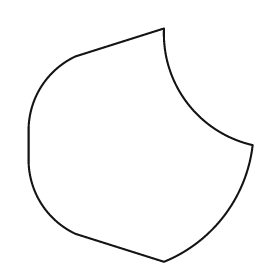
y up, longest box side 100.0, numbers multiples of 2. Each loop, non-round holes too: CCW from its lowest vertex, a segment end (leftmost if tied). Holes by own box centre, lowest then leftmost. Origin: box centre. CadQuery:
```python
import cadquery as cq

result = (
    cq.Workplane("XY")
    .moveTo(10.0, -50.0)
    .threePointArc((36.0, -30.0), (48.0, 0.0))
    .threePointArc((20.0, 18.0), (10.0, 50.0))
    .lineTo(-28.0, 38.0)
    .threePointArc((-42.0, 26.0), (-48.0, 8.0))
    .lineTo(-48.0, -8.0)
    .threePointArc((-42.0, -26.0), (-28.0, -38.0))
    .close()
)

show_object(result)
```